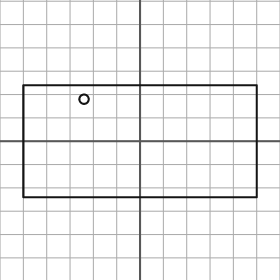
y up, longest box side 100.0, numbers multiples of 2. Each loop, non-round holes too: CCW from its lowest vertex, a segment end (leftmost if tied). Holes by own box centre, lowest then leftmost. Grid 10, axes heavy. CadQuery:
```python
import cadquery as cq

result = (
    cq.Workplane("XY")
    .moveTo(-50.0, -24.0)
    .lineTo(50.0, -24.0)
    .lineTo(50.0, 24.0)
    .lineTo(-50.0, 24.0)
    .close()
    .moveTo(-24.0, 18.0)
    .circle(2.0)
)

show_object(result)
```